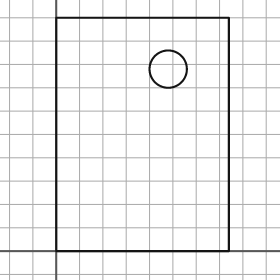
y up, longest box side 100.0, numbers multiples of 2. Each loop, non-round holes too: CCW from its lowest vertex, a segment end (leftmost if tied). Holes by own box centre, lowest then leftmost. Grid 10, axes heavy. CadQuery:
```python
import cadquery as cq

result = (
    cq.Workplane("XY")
    .moveTo(0.0, 0.0)
    .lineTo(74.0, 0.0)
    .lineTo(74.0, 100.0)
    .lineTo(0.0, 100.0)
    .close()
    .moveTo(48.0, 78.0)
    .circle(8.0)
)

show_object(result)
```